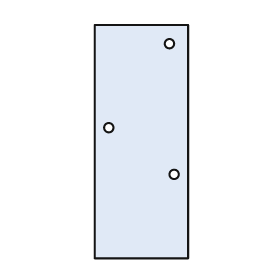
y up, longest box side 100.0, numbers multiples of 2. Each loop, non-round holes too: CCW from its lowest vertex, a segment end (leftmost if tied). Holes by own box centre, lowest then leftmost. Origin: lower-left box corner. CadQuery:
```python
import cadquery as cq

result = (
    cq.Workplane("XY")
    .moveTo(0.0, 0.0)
    .lineTo(40.0, 0.0)
    .lineTo(40.0, 100.0)
    .lineTo(0.0, 100.0)
    .close()
    .moveTo(34.0, 36.0)
    .circle(2.0)
    .moveTo(6.0, 56.0)
    .circle(2.0)
    .moveTo(32.0, 92.0)
    .circle(2.0)
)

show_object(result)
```